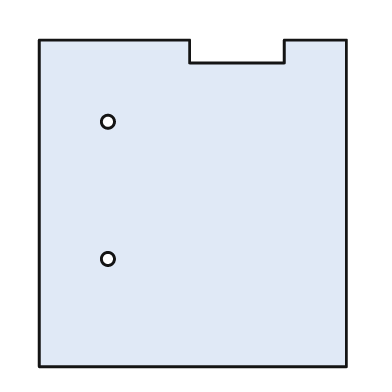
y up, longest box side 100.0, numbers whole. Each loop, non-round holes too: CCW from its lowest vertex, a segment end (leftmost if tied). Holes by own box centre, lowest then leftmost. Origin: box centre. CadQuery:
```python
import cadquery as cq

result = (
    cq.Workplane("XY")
    .moveTo(-47.0, -50.0)
    .lineTo(47.0, -50.0)
    .lineTo(47.0, 50.0)
    .lineTo(28.0, 50.0)
    .lineTo(28.0, 43.0)
    .lineTo(-1.0, 43.0)
    .lineTo(-1.0, 50.0)
    .lineTo(-47.0, 50.0)
    .close()
    .moveTo(-26.0, -17.0)
    .circle(2.0)
    .moveTo(-26.0, 25.0)
    .circle(2.0)
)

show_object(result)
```